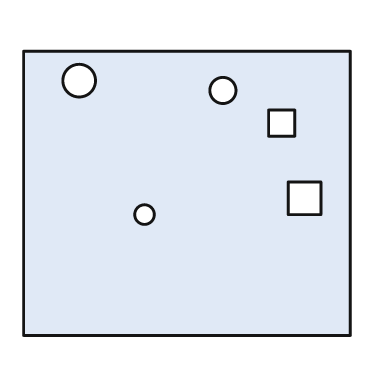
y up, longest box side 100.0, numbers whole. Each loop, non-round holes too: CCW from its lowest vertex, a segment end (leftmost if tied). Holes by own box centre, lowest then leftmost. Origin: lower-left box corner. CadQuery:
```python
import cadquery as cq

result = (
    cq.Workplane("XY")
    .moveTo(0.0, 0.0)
    .lineTo(100.0, 0.0)
    .lineTo(100.0, 87.0)
    .lineTo(0.0, 87.0)
    .close()
    .moveTo(37.0, 37.0)
    .circle(3.0)
    .moveTo(81.0, 37.0)
    .lineTo(91.0, 37.0)
    .lineTo(91.0, 47.0)
    .lineTo(81.0, 47.0)
    .close()
    .moveTo(75.0, 61.0)
    .lineTo(83.0, 61.0)
    .lineTo(83.0, 69.0)
    .lineTo(75.0, 69.0)
    .close()
    .moveTo(61.0, 75.0)
    .circle(4.0)
    .moveTo(17.0, 78.0)
    .circle(5.0)
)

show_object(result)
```